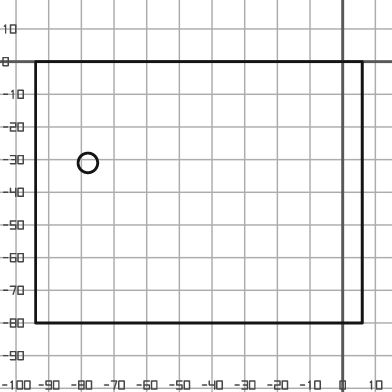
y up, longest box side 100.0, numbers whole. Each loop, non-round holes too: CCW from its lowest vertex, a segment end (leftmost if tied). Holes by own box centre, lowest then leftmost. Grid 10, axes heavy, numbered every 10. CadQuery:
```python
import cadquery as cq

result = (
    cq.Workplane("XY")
    .moveTo(-94.0, -80.0)
    .lineTo(6.0, -80.0)
    .lineTo(6.0, 0.0)
    .lineTo(-94.0, 0.0)
    .close()
    .moveTo(-78.0, -31.0)
    .circle(3.0)
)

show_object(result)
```